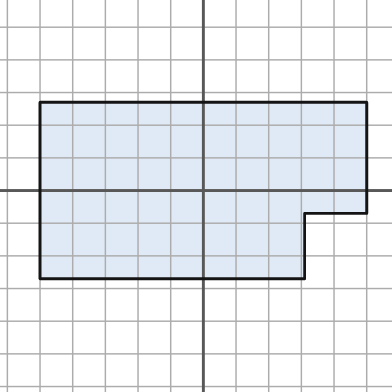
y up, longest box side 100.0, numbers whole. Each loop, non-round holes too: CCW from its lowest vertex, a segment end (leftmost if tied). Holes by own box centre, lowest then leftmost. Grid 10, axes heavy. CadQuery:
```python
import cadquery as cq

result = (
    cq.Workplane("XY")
    .moveTo(-50.0, -27.0)
    .lineTo(31.0, -27.0)
    .lineTo(31.0, -7.0)
    .lineTo(50.0, -7.0)
    .lineTo(50.0, 27.0)
    .lineTo(-50.0, 27.0)
    .close()
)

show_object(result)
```